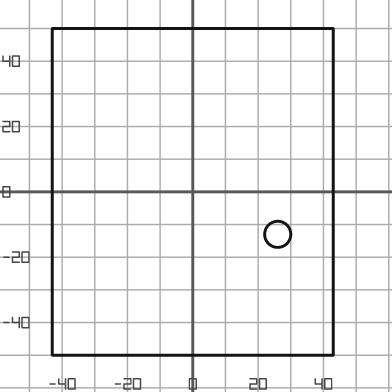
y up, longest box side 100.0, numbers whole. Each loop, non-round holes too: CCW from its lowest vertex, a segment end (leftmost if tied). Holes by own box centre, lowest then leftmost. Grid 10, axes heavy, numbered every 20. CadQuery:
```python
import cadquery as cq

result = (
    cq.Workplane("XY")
    .moveTo(-43.0, -50.0)
    .lineTo(43.0, -50.0)
    .lineTo(43.0, 50.0)
    .lineTo(-43.0, 50.0)
    .close()
    .moveTo(26.0, -13.0)
    .circle(4.0)
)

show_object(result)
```